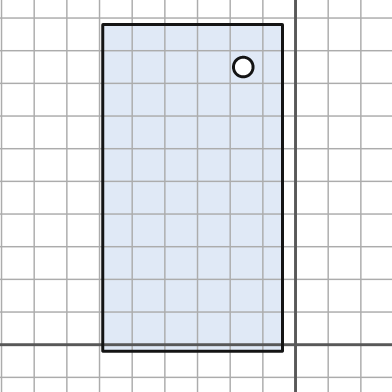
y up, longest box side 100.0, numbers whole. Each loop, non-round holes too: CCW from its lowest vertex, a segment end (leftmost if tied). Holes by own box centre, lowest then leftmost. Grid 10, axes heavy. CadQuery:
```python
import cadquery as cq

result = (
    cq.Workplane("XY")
    .moveTo(-59.0, -2.0)
    .lineTo(-4.0, -2.0)
    .lineTo(-4.0, 98.0)
    .lineTo(-59.0, 98.0)
    .close()
    .moveTo(-16.0, 85.0)
    .circle(3.0)
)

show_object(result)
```